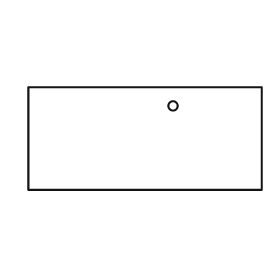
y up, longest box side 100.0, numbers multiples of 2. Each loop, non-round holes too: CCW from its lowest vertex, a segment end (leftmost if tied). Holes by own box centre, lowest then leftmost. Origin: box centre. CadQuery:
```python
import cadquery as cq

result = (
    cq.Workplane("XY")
    .moveTo(-50.0, -22.0)
    .lineTo(50.0, -22.0)
    .lineTo(50.0, 22.0)
    .lineTo(-50.0, 22.0)
    .close()
    .moveTo(12.0, 14.0)
    .circle(2.0)
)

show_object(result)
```